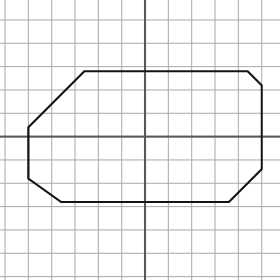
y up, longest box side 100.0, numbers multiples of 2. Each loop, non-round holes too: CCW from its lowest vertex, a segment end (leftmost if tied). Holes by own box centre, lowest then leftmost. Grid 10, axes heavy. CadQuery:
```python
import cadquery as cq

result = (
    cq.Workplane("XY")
    .moveTo(-36.0, -28.0)
    .lineTo(36.0, -28.0)
    .lineTo(50.0, -14.0)
    .lineTo(50.0, 22.0)
    .lineTo(44.0, 28.0)
    .lineTo(-26.0, 28.0)
    .lineTo(-50.0, 4.0)
    .lineTo(-50.0, -18.0)
    .close()
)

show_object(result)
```